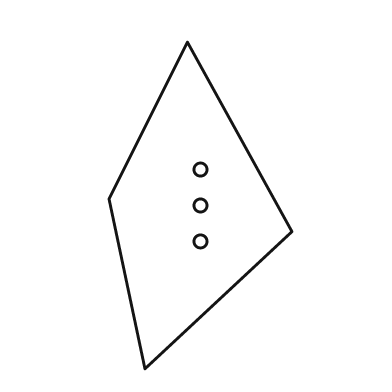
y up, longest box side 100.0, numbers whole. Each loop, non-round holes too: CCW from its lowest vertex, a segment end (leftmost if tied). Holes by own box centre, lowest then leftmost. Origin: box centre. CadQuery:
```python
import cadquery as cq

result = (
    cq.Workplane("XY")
    .moveTo(-17.0, -50.0)
    .lineTo(28.0, -8.0)
    .lineTo(-4.0, 50.0)
    .lineTo(-28.0, 2.0)
    .close()
    .moveTo(0.0, -11.0)
    .circle(2.0)
    .moveTo(0.0, 0.0)
    .circle(2.0)
    .moveTo(0.0, 11.0)
    .circle(2.0)
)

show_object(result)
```